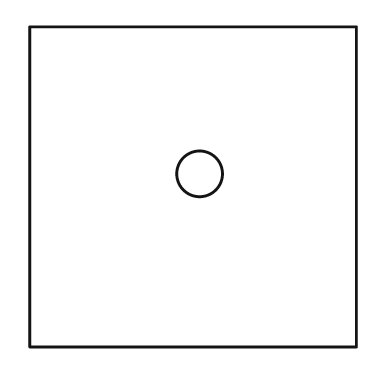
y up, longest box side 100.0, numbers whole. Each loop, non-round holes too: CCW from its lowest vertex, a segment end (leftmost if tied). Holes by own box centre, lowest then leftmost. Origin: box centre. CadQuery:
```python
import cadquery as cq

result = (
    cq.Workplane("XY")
    .moveTo(-50.0, -49.0)
    .lineTo(50.0, -49.0)
    .lineTo(50.0, 49.0)
    .lineTo(-50.0, 49.0)
    .close()
    .moveTo(2.0, 4.0)
    .circle(7.0)
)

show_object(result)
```